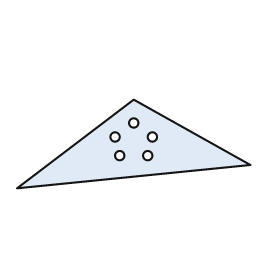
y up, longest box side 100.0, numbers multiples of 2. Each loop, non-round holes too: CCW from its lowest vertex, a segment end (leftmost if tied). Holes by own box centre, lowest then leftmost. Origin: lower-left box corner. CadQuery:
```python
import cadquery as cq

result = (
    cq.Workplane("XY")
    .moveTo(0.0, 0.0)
    .lineTo(100.0, 10.0)
    .lineTo(50.0, 38.0)
    .close()
    .moveTo(44.0, 14.0)
    .circle(2.0)
    .moveTo(56.0, 14.0)
    .circle(2.0)
    .moveTo(42.0, 22.0)
    .circle(2.0)
    .moveTo(58.0, 22.0)
    .circle(2.0)
    .moveTo(50.0, 28.0)
    .circle(2.0)
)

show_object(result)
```